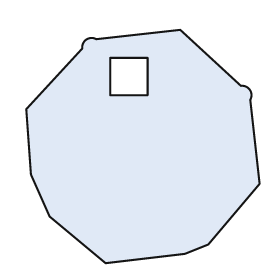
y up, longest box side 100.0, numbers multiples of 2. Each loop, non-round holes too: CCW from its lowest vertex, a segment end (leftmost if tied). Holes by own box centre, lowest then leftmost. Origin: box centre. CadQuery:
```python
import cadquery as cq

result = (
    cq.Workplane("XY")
    .moveTo(-16.0, -50.0)
    .lineTo(18.0, -46.0)
    .lineTo(28.0, -42.0)
    .lineTo(50.0, -16.0)
    .lineTo(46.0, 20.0)
    .threePointArc((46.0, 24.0), (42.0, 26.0))
    .lineTo(16.0, 50.0)
    .lineTo(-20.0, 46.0)
    .threePointArc((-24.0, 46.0), (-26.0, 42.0))
    .lineTo(-50.0, 16.0)
    .lineTo(-48.0, -12.0)
    .lineTo(-40.0, -30.0)
    .close()
    .moveTo(-14.0, 22.0)
    .lineTo(2.0, 22.0)
    .lineTo(2.0, 38.0)
    .lineTo(-14.0, 38.0)
    .close()
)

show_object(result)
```